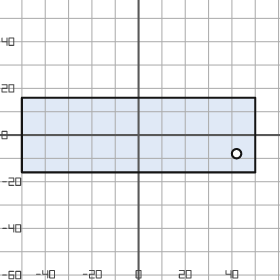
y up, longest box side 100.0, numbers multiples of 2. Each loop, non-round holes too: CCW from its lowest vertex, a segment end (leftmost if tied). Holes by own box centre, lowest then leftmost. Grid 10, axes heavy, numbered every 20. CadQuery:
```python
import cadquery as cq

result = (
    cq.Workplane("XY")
    .moveTo(-50.0, -16.0)
    .lineTo(50.0, -16.0)
    .lineTo(50.0, 16.0)
    .lineTo(-50.0, 16.0)
    .close()
    .moveTo(42.0, -8.0)
    .circle(2.0)
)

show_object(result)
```